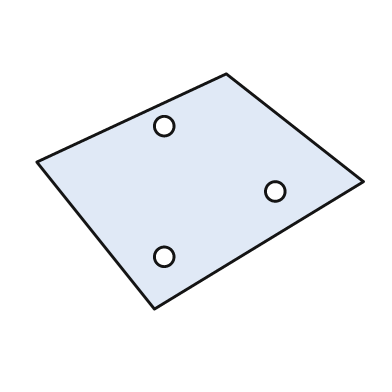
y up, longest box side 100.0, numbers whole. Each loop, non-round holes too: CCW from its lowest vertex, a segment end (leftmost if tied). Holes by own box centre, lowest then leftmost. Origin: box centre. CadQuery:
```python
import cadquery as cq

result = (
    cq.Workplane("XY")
    .moveTo(-14.0, -36.0)
    .lineTo(50.0, 3.0)
    .lineTo(8.0, 36.0)
    .lineTo(-50.0, 9.0)
    .close()
    .moveTo(-11.0, -20.0)
    .circle(3.0)
    .moveTo(23.0, 0.0)
    .circle(3.0)
    .moveTo(-11.0, 20.0)
    .circle(3.0)
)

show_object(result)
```